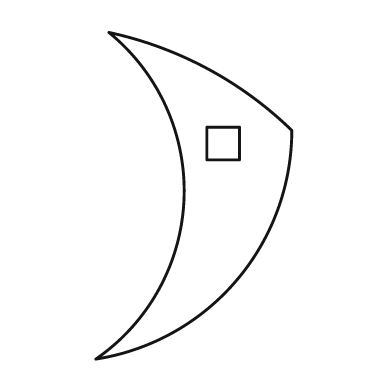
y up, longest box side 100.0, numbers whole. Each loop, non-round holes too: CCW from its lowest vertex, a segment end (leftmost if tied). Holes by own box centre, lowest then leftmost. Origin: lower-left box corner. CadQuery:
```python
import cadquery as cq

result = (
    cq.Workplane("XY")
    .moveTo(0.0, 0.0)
    .threePointArc((43.0, 24.0), (60.0, 70.0))
    .threePointArc((34.0, 89.0), (4.0, 100.0))
    .threePointArc((27.0, 49.0), (0.0, 0.0))
    .close()
    .moveTo(34.0, 61.0)
    .lineTo(44.0, 61.0)
    .lineTo(44.0, 71.0)
    .lineTo(34.0, 71.0)
    .close()
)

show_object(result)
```